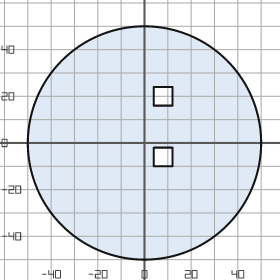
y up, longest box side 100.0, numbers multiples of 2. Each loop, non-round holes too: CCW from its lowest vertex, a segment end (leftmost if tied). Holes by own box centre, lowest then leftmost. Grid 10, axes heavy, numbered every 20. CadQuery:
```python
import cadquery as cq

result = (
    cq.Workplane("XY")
    .moveTo(0.0, 0.0)
    .circle(50.0)
    .moveTo(4.0, -10.0)
    .lineTo(12.0, -10.0)
    .lineTo(12.0, -2.0)
    .lineTo(4.0, -2.0)
    .close()
    .moveTo(4.0, 16.0)
    .lineTo(12.0, 16.0)
    .lineTo(12.0, 24.0)
    .lineTo(4.0, 24.0)
    .close()
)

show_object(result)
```